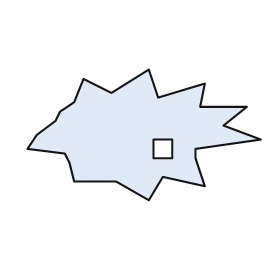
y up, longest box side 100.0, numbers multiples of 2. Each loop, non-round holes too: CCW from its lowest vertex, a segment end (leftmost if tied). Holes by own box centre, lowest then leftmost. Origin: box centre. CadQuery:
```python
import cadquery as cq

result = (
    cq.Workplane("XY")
    .moveTo(2.0, -28.0)
    .lineTo(8.0, -18.0)
    .lineTo(26.0, -22.0)
    .lineTo(22.0, -10.0)
    .lineTo(22.0, -6.0)
    .lineTo(50.0, -2.0)
    .lineTo(34.0, 4.0)
    .lineTo(44.0, 12.0)
    .lineTo(24.0, 12.0)
    .lineTo(26.0, 22.0)
    .lineTo(6.0, 16.0)
    .lineTo(2.0, 28.0)
    .lineTo(-14.0, 18.0)
    .lineTo(-26.0, 24.0)
    .lineTo(-30.0, 14.0)
    .lineTo(-36.0, 10.0)
    .lineTo(-38.0, 6.0)
    .lineTo(-46.0, 0.0)
    .lineTo(-50.0, -6.0)
    .lineTo(-34.0, -8.0)
    .lineTo(-32.0, -12.0)
    .lineTo(-30.0, -20.0)
    .lineTo(-12.0, -20.0)
    .close()
    .moveTo(4.0, -10.0)
    .lineTo(12.0, -10.0)
    .lineTo(12.0, -2.0)
    .lineTo(4.0, -2.0)
    .close()
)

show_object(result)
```